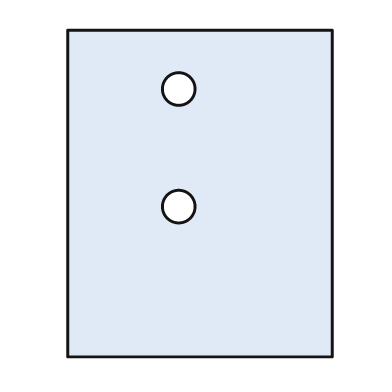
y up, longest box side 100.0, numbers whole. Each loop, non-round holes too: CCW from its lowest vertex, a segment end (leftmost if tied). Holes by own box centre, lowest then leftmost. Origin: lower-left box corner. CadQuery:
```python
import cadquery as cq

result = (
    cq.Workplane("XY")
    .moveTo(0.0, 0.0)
    .lineTo(81.0, 0.0)
    .lineTo(81.0, 100.0)
    .lineTo(0.0, 100.0)
    .close()
    .moveTo(34.0, 46.0)
    .circle(5.0)
    .moveTo(34.0, 82.0)
    .circle(5.0)
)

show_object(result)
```